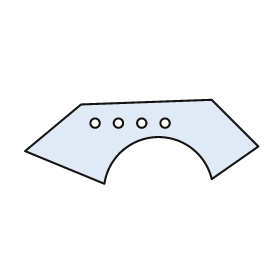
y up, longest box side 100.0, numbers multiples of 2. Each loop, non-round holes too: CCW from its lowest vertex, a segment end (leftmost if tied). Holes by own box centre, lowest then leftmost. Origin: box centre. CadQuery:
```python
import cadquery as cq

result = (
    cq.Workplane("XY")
    .moveTo(-16.0, -18.0)
    .threePointArc((6.0, 2.0), (30.0, -16.0))
    .lineTo(50.0, -2.0)
    .lineTo(30.0, 18.0)
    .lineTo(-26.0, 16.0)
    .lineTo(-50.0, -4.0)
    .close()
    .moveTo(-20.0, 8.0)
    .circle(2.0)
    .moveTo(-10.0, 8.0)
    .circle(2.0)
    .moveTo(0.0, 8.0)
    .circle(2.0)
    .moveTo(10.0, 8.0)
    .circle(2.0)
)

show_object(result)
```